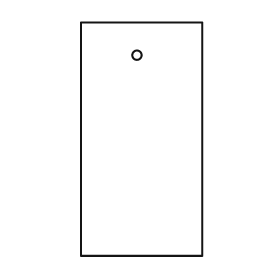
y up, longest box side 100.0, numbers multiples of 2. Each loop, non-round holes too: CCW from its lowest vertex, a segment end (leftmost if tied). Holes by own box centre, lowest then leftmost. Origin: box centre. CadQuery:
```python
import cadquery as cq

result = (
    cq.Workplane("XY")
    .moveTo(-26.0, -50.0)
    .lineTo(26.0, -50.0)
    .lineTo(26.0, 50.0)
    .lineTo(-26.0, 50.0)
    .close()
    .moveTo(-2.0, 36.0)
    .circle(2.0)
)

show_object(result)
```